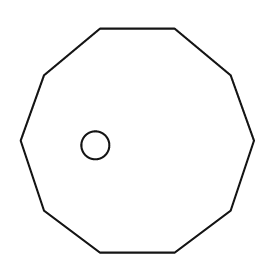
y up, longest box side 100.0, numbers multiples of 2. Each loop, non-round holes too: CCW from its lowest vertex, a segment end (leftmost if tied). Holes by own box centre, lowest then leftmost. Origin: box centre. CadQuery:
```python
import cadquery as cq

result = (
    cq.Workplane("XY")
    .moveTo(-16.0, -48.0)
    .lineTo(16.0, -48.0)
    .lineTo(40.0, -30.0)
    .lineTo(50.0, 0.0)
    .lineTo(40.0, 28.0)
    .lineTo(16.0, 48.0)
    .lineTo(-16.0, 48.0)
    .lineTo(-40.0, 28.0)
    .lineTo(-50.0, 0.0)
    .lineTo(-40.0, -30.0)
    .close()
    .moveTo(-18.0, -2.0)
    .circle(6.0)
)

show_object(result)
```